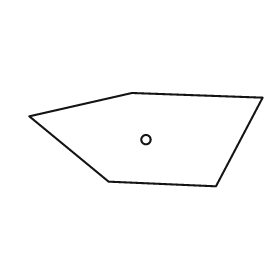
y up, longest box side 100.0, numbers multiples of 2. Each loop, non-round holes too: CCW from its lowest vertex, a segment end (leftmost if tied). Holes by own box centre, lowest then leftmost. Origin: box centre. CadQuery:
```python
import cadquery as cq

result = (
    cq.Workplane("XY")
    .moveTo(30.0, -20.0)
    .lineTo(50.0, 18.0)
    .lineTo(-6.0, 20.0)
    .lineTo(-50.0, 10.0)
    .lineTo(-16.0, -18.0)
    .close()
    .moveTo(0.0, 0.0)
    .circle(2.0)
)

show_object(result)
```